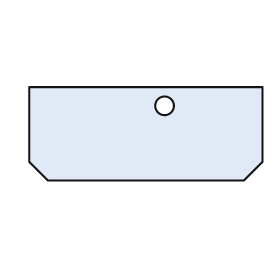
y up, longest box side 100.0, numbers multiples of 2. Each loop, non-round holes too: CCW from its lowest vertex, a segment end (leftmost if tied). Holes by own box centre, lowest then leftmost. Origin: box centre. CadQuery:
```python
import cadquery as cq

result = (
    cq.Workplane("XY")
    .moveTo(-42.0, -20.0)
    .lineTo(42.0, -20.0)
    .lineTo(50.0, -12.0)
    .lineTo(50.0, 20.0)
    .lineTo(-50.0, 20.0)
    .lineTo(-50.0, -12.0)
    .close()
    .moveTo(8.0, 12.0)
    .circle(4.0)
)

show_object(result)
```